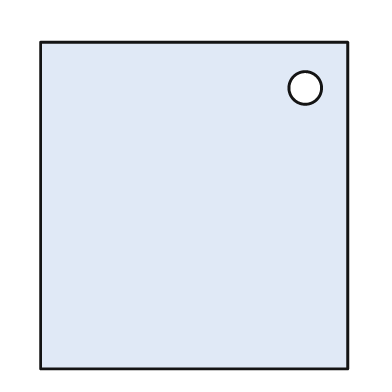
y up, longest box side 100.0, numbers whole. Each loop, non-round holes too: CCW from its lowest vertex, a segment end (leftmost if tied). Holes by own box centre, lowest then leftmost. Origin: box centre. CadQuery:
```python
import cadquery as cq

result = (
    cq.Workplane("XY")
    .moveTo(-47.0, -50.0)
    .lineTo(47.0, -50.0)
    .lineTo(47.0, 50.0)
    .lineTo(-47.0, 50.0)
    .close()
    .moveTo(34.0, 36.0)
    .circle(5.0)
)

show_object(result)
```